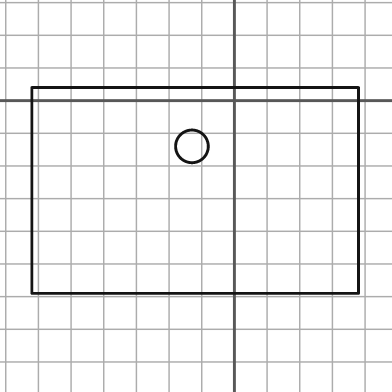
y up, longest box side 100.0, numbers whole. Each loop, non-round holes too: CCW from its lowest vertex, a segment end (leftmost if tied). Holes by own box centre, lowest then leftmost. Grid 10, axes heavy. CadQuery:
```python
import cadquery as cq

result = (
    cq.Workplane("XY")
    .moveTo(-62.0, -59.0)
    .lineTo(38.0, -59.0)
    .lineTo(38.0, 4.0)
    .lineTo(-62.0, 4.0)
    .close()
    .moveTo(-13.0, -14.0)
    .circle(5.0)
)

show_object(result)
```